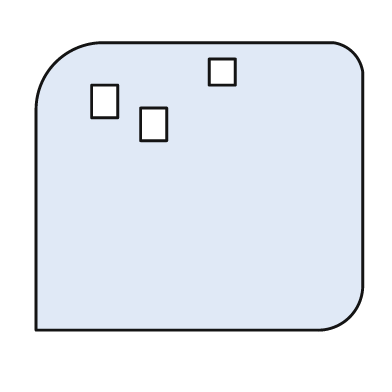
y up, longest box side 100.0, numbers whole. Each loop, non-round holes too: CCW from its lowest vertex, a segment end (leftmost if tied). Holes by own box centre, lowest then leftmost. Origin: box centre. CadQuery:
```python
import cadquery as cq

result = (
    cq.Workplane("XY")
    .moveTo(-50.0, -44.0)
    .lineTo(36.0, -44.0)
    .threePointArc((46.0, -40.0), (50.0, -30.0))
    .lineTo(50.0, 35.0)
    .threePointArc((47.0, 41.0), (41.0, 44.0))
    .lineTo(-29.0, 44.0)
    .threePointArc((-44.0, 38.0), (-50.0, 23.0))
    .close()
    .moveTo(-18.0, 14.0)
    .lineTo(-10.0, 14.0)
    .lineTo(-10.0, 24.0)
    .lineTo(-18.0, 24.0)
    .close()
    .moveTo(-33.0, 21.0)
    .lineTo(-25.0, 21.0)
    .lineTo(-25.0, 31.0)
    .lineTo(-33.0, 31.0)
    .close()
    .moveTo(3.0, 31.0)
    .lineTo(11.0, 31.0)
    .lineTo(11.0, 39.0)
    .lineTo(3.0, 39.0)
    .close()
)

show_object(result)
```